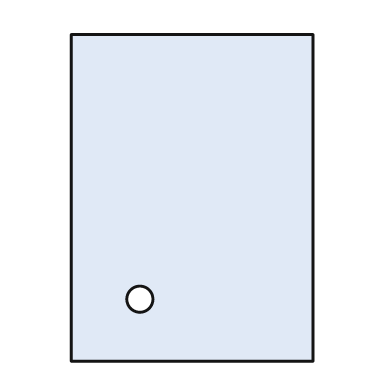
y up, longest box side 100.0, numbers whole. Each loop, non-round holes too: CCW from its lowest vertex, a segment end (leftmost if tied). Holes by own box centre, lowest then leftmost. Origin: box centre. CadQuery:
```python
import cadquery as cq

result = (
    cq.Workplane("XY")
    .moveTo(-37.0, -50.0)
    .lineTo(37.0, -50.0)
    .lineTo(37.0, 50.0)
    .lineTo(-37.0, 50.0)
    .close()
    .moveTo(-16.0, -31.0)
    .circle(4.0)
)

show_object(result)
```